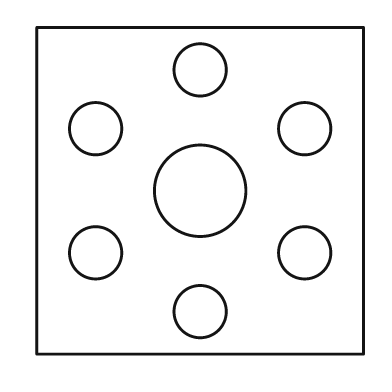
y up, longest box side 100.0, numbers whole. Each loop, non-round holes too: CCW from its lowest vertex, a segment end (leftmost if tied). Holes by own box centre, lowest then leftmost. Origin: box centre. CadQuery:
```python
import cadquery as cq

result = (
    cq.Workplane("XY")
    .moveTo(-50.0, -50.0)
    .lineTo(50.0, -50.0)
    .lineTo(50.0, 50.0)
    .lineTo(-50.0, 50.0)
    .close()
    .moveTo(0.0, -37.0)
    .circle(8.0)
    .moveTo(-32.0, -19.0)
    .circle(8.0)
    .moveTo(32.0, -19.0)
    .circle(8.0)
    .moveTo(0.0, 0.0)
    .circle(14.0)
    .moveTo(-32.0, 19.0)
    .circle(8.0)
    .moveTo(32.0, 19.0)
    .circle(8.0)
    .moveTo(0.0, 37.0)
    .circle(8.0)
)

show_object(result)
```